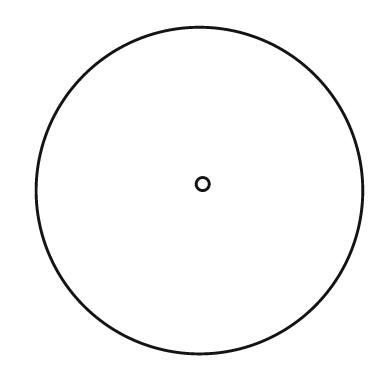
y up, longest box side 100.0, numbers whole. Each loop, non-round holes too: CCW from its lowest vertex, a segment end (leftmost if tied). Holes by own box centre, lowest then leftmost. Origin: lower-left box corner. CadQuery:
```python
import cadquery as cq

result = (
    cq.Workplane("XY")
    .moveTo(50.0, 50.0)
    .circle(50.0)
    .moveTo(51.0, 52.0)
    .circle(2.0)
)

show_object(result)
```